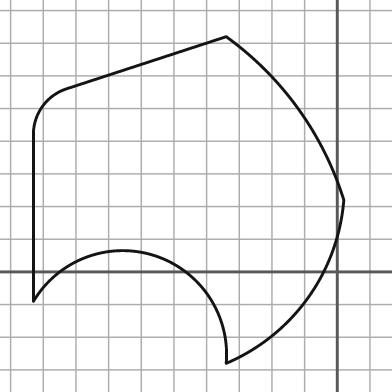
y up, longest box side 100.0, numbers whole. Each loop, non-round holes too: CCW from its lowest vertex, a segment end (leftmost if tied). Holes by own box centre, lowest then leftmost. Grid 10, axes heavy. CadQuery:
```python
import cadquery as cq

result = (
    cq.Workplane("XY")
    .moveTo(-34.0, -28.0)
    .threePointArc((-9.0, -8.0), (2.0, 22.0))
    .threePointArc((-12.0, 50.0), (-34.0, 72.0))
    .lineTo(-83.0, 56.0)
    .threePointArc((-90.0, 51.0), (-93.0, 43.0))
    .lineTo(-93.0, -9.0)
    .threePointArc((-56.0, 5.0), (-34.0, -28.0))
    .close()
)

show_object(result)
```